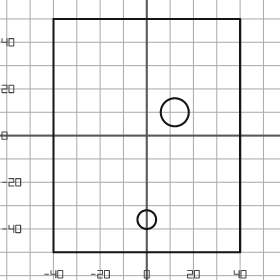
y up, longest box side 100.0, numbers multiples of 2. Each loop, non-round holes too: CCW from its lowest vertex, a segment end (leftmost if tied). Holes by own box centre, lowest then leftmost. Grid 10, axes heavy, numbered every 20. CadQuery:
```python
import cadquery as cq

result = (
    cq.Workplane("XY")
    .moveTo(-40.0, -50.0)
    .lineTo(40.0, -50.0)
    .lineTo(40.0, 50.0)
    .lineTo(-40.0, 50.0)
    .close()
    .moveTo(0.0, -36.0)
    .circle(4.0)
    .moveTo(12.0, 10.0)
    .circle(6.0)
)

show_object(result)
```